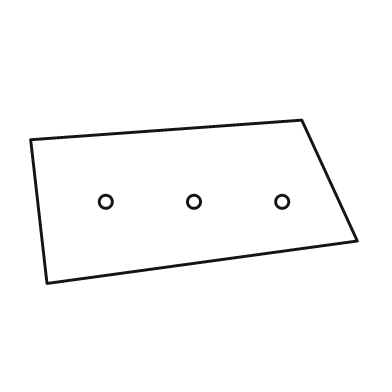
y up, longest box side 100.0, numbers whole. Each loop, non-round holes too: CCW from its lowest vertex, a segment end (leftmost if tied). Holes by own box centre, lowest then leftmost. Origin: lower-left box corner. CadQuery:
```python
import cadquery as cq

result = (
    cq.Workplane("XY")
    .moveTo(5.0, 0.0)
    .lineTo(100.0, 13.0)
    .lineTo(83.0, 50.0)
    .lineTo(0.0, 44.0)
    .close()
    .moveTo(23.0, 25.0)
    .circle(2.0)
    .moveTo(50.0, 25.0)
    .circle(2.0)
    .moveTo(77.0, 25.0)
    .circle(2.0)
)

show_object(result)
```